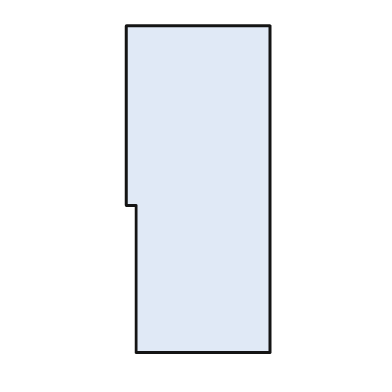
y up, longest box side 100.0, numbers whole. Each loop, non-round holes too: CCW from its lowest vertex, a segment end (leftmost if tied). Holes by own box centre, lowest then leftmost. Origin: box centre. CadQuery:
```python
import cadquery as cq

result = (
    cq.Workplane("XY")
    .moveTo(-19.0, -50.0)
    .lineTo(22.0, -50.0)
    .lineTo(22.0, 50.0)
    .lineTo(-22.0, 50.0)
    .lineTo(-22.0, -5.0)
    .lineTo(-19.0, -5.0)
    .close()
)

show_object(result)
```